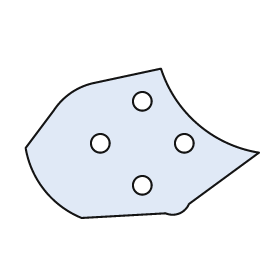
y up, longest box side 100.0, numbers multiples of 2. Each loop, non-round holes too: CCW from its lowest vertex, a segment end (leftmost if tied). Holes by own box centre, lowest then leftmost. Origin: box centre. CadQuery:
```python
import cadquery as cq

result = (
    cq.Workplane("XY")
    .moveTo(-26.0, -32.0)
    .lineTo(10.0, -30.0)
    .threePointArc((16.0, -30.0), (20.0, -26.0))
    .lineTo(50.0, -4.0)
    .threePointArc((24.0, 8.0), (8.0, 32.0))
    .lineTo(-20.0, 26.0)
    .threePointArc((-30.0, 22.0), (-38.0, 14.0))
    .lineTo(-50.0, -2.0)
    .threePointArc((-42.0, -20.0), (-26.0, -32.0))
    .close()
    .moveTo(0.0, -18.0)
    .circle(4.0)
    .moveTo(-18.0, 0.0)
    .circle(4.0)
    .moveTo(18.0, 0.0)
    .circle(4.0)
    .moveTo(0.0, 18.0)
    .circle(4.0)
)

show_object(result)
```